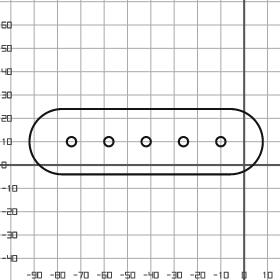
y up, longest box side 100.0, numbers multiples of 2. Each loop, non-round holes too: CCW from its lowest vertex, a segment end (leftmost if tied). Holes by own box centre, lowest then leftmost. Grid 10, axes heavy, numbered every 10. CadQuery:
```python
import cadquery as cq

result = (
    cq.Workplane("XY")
    .moveTo(-78.0, -4.0)
    .lineTo(-6.0, -4.0)
    .threePointArc((8.0, 10.0), (-6.0, 24.0))
    .lineTo(-78.0, 24.0)
    .threePointArc((-92.0, 10.0), (-78.0, -4.0))
    .close()
    .moveTo(-74.0, 10.0)
    .circle(2.0)
    .moveTo(-58.0, 10.0)
    .circle(2.0)
    .moveTo(-42.0, 10.0)
    .circle(2.0)
    .moveTo(-26.0, 10.0)
    .circle(2.0)
    .moveTo(-10.0, 10.0)
    .circle(2.0)
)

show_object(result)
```